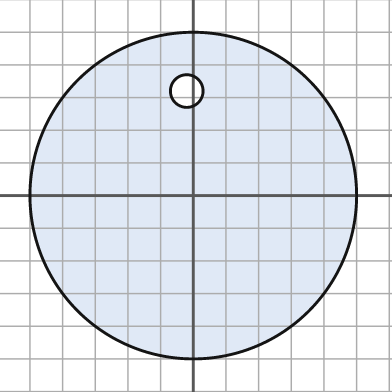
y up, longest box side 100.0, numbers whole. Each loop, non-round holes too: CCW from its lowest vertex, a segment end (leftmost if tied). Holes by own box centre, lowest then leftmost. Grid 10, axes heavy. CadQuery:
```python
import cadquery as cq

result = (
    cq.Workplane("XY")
    .moveTo(0.0, 0.0)
    .circle(50.0)
    .moveTo(-2.0, 32.0)
    .circle(5.0)
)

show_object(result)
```